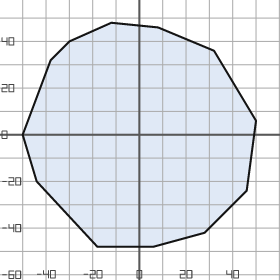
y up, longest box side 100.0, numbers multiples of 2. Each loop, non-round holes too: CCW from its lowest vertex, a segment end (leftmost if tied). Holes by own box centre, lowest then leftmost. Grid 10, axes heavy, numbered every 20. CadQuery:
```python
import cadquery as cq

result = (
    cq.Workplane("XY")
    .moveTo(-18.0, -48.0)
    .lineTo(6.0, -48.0)
    .lineTo(28.0, -42.0)
    .lineTo(46.0, -24.0)
    .lineTo(50.0, 6.0)
    .lineTo(32.0, 36.0)
    .lineTo(8.0, 46.0)
    .lineTo(-12.0, 48.0)
    .lineTo(-30.0, 40.0)
    .lineTo(-38.0, 32.0)
    .lineTo(-50.0, 0.0)
    .lineTo(-44.0, -20.0)
    .close()
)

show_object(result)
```